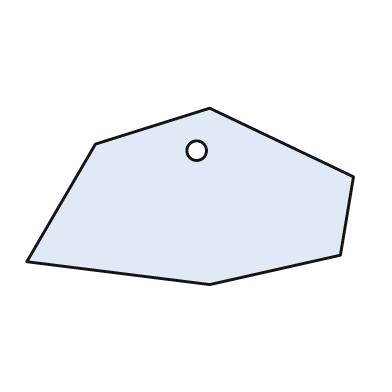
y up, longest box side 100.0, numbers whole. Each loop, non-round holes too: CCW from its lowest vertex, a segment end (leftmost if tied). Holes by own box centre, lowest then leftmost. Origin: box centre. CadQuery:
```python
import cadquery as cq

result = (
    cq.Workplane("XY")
    .moveTo(6.0, -27.0)
    .lineTo(46.0, -18.0)
    .lineTo(50.0, 6.0)
    .lineTo(6.0, 27.0)
    .lineTo(-29.0, 16.0)
    .lineTo(-50.0, -20.0)
    .close()
    .moveTo(2.0, 14.0)
    .circle(3.0)
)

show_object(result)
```